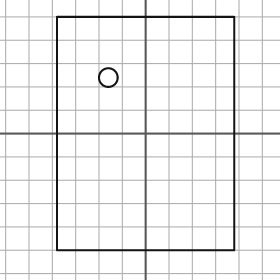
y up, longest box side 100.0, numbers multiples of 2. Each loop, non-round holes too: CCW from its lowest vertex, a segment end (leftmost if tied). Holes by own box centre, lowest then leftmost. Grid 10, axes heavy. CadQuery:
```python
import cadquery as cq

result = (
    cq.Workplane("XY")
    .moveTo(-38.0, -50.0)
    .lineTo(38.0, -50.0)
    .lineTo(38.0, 50.0)
    .lineTo(-38.0, 50.0)
    .close()
    .moveTo(-16.0, 24.0)
    .circle(4.0)
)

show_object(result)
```